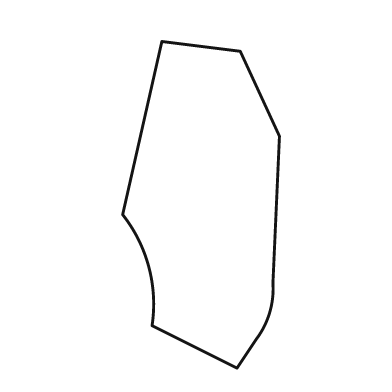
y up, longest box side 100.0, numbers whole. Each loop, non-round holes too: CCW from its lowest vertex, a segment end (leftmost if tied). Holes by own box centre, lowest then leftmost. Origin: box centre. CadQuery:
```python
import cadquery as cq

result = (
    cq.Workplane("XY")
    .moveTo(11.0, -50.0)
    .lineTo(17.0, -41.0)
    .threePointArc((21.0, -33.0), (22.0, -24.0))
    .lineTo(24.0, 21.0)
    .lineTo(12.0, 47.0)
    .lineTo(-12.0, 50.0)
    .lineTo(-24.0, -3.0)
    .threePointArc((-16.0, -19.0), (-15.0, -37.0))
    .close()
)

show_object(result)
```